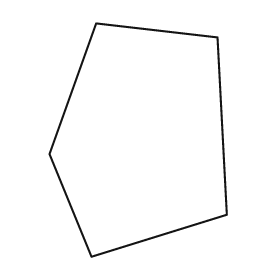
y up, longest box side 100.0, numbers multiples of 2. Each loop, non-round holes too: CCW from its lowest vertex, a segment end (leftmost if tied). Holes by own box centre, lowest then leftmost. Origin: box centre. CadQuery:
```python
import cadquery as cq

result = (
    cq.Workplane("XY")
    .moveTo(-20.0, -50.0)
    .lineTo(38.0, -32.0)
    .lineTo(34.0, 44.0)
    .lineTo(-18.0, 50.0)
    .lineTo(-38.0, -6.0)
    .close()
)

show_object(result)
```